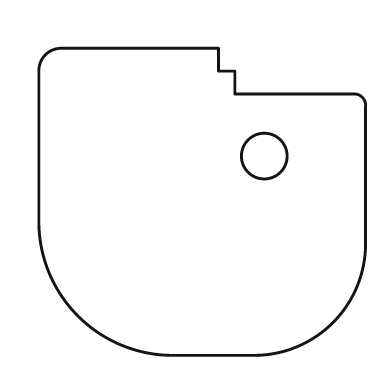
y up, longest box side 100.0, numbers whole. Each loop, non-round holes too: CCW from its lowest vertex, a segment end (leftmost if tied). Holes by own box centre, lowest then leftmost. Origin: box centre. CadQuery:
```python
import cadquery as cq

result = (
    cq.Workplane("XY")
    .moveTo(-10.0, -47.0)
    .lineTo(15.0, -47.0)
    .threePointArc((40.0, -37.0), (50.0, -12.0))
    .lineTo(50.0, 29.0)
    .threePointArc((49.0, 32.0), (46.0, 33.0))
    .lineTo(10.0, 33.0)
    .lineTo(10.0, 40.0)
    .lineTo(5.0, 40.0)
    .lineTo(5.0, 47.0)
    .lineTo(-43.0, 47.0)
    .threePointArc((-48.0, 45.0), (-50.0, 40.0))
    .lineTo(-50.0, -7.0)
    .threePointArc((-38.0, -35.0), (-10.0, -47.0))
    .close()
    .moveTo(19.0, 14.0)
    .circle(7.0)
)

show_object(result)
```